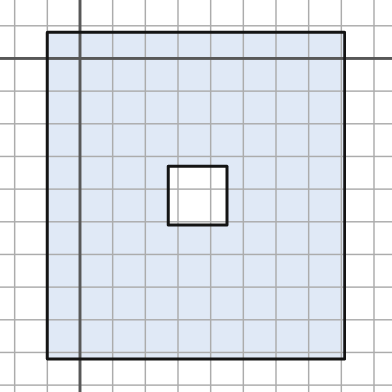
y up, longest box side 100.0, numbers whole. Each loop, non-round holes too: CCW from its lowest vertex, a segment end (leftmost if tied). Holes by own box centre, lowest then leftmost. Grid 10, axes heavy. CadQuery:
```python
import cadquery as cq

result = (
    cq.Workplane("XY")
    .moveTo(-10.0, -92.0)
    .lineTo(81.0, -92.0)
    .lineTo(81.0, 8.0)
    .lineTo(-10.0, 8.0)
    .close()
    .moveTo(27.0, -51.0)
    .lineTo(45.0, -51.0)
    .lineTo(45.0, -33.0)
    .lineTo(27.0, -33.0)
    .close()
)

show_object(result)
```